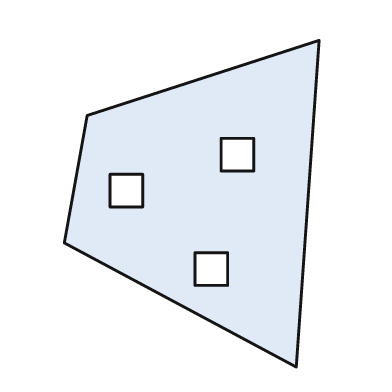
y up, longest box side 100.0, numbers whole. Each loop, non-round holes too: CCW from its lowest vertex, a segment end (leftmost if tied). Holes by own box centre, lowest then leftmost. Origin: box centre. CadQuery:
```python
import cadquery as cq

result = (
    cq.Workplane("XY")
    .moveTo(32.0, -50.0)
    .lineTo(39.0, 50.0)
    .lineTo(-32.0, 27.0)
    .lineTo(-39.0, -12.0)
    .close()
    .moveTo(1.0, -25.0)
    .lineTo(11.0, -25.0)
    .lineTo(11.0, -15.0)
    .lineTo(1.0, -15.0)
    .close()
    .moveTo(-25.0, -1.0)
    .lineTo(-15.0, -1.0)
    .lineTo(-15.0, 9.0)
    .lineTo(-25.0, 9.0)
    .close()
    .moveTo(9.0, 10.0)
    .lineTo(19.0, 10.0)
    .lineTo(19.0, 20.0)
    .lineTo(9.0, 20.0)
    .close()
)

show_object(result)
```